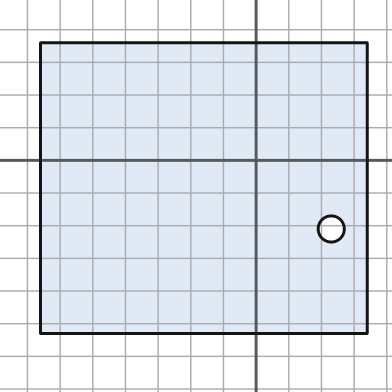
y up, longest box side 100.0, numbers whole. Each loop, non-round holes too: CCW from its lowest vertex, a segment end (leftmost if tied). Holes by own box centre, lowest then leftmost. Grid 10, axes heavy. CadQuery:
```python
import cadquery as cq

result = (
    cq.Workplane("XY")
    .moveTo(-66.0, -53.0)
    .lineTo(34.0, -53.0)
    .lineTo(34.0, 36.0)
    .lineTo(-66.0, 36.0)
    .close()
    .moveTo(23.0, -21.0)
    .circle(4.0)
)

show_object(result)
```